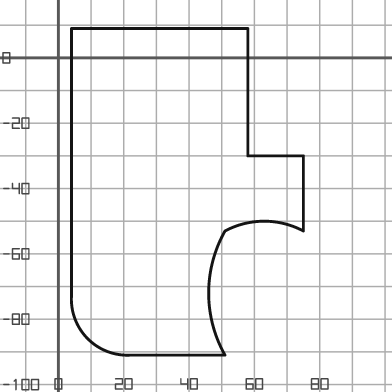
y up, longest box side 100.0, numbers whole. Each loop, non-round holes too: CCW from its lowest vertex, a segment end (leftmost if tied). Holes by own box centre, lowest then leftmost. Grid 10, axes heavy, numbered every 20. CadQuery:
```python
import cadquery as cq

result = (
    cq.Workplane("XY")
    .moveTo(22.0, -91.0)
    .lineTo(51.0, -91.0)
    .threePointArc((46.0, -72.0), (51.0, -53.0))
    .threePointArc((63.0, -50.0), (75.0, -53.0))
    .lineTo(75.0, -30.0)
    .lineTo(58.0, -30.0)
    .lineTo(58.0, 9.0)
    .lineTo(4.0, 9.0)
    .lineTo(4.0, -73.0)
    .threePointArc((9.0, -86.0), (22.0, -91.0))
    .close()
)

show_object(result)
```